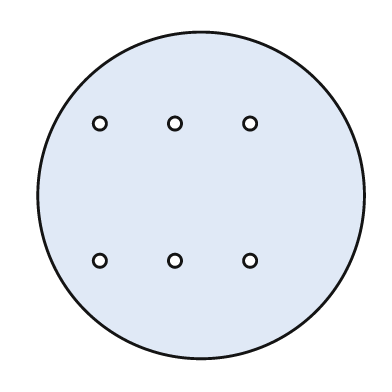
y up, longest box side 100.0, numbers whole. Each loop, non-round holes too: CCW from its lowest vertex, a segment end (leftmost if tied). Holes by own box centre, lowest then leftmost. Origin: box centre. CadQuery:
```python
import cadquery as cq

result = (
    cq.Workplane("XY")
    .moveTo(0.0, 0.0)
    .circle(50.0)
    .moveTo(-31.0, -20.0)
    .circle(2.0)
    .moveTo(-8.0, -20.0)
    .circle(2.0)
    .moveTo(15.0, -20.0)
    .circle(2.0)
    .moveTo(-31.0, 22.0)
    .circle(2.0)
    .moveTo(-8.0, 22.0)
    .circle(2.0)
    .moveTo(15.0, 22.0)
    .circle(2.0)
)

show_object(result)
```